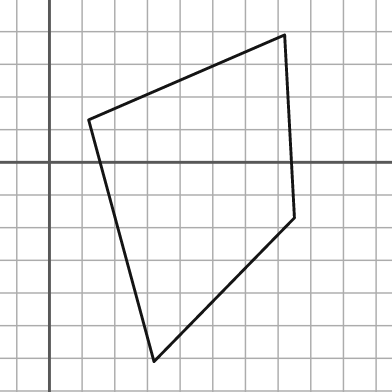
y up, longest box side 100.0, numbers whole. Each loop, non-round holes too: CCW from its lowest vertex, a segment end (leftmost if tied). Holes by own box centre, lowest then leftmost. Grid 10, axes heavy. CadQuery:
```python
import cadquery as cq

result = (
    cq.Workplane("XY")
    .moveTo(32.0, -61.0)
    .lineTo(75.0, -17.0)
    .lineTo(72.0, 39.0)
    .lineTo(12.0, 13.0)
    .close()
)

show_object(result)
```